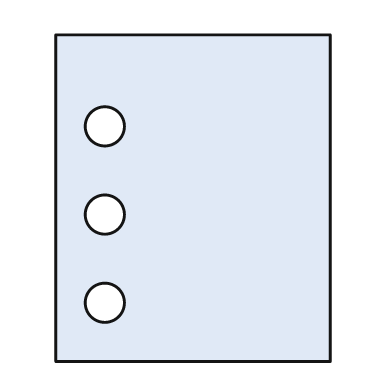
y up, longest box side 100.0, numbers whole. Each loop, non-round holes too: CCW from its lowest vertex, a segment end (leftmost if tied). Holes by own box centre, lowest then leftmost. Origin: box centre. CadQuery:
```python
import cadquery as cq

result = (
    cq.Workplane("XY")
    .moveTo(-42.0, -50.0)
    .lineTo(42.0, -50.0)
    .lineTo(42.0, 50.0)
    .lineTo(-42.0, 50.0)
    .close()
    .moveTo(-27.0, -32.0)
    .circle(6.0)
    .moveTo(-27.0, -5.0)
    .circle(6.0)
    .moveTo(-27.0, 22.0)
    .circle(6.0)
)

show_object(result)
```